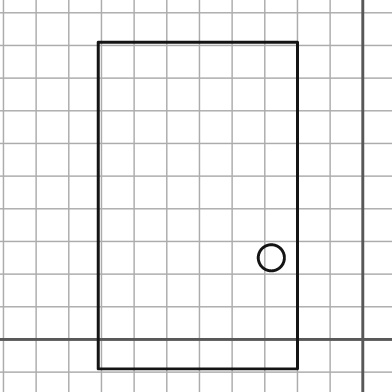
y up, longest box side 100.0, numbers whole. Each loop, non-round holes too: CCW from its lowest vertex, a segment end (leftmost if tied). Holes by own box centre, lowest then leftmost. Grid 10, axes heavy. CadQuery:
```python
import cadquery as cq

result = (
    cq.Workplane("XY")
    .moveTo(-81.0, -9.0)
    .lineTo(-20.0, -9.0)
    .lineTo(-20.0, 91.0)
    .lineTo(-81.0, 91.0)
    .close()
    .moveTo(-28.0, 25.0)
    .circle(4.0)
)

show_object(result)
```